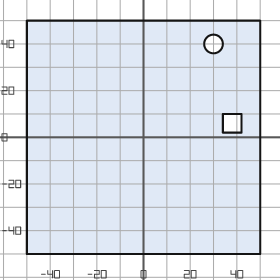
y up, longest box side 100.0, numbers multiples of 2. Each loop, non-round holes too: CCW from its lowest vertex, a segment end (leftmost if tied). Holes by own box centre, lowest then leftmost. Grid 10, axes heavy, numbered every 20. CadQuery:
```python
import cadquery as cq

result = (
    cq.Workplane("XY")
    .moveTo(-50.0, -50.0)
    .lineTo(50.0, -50.0)
    .lineTo(50.0, 50.0)
    .lineTo(-50.0, 50.0)
    .close()
    .moveTo(34.0, 2.0)
    .lineTo(42.0, 2.0)
    .lineTo(42.0, 10.0)
    .lineTo(34.0, 10.0)
    .close()
    .moveTo(30.0, 40.0)
    .circle(4.0)
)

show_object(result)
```